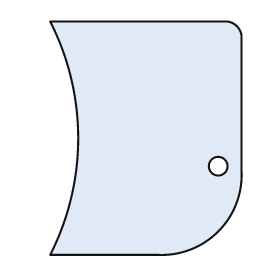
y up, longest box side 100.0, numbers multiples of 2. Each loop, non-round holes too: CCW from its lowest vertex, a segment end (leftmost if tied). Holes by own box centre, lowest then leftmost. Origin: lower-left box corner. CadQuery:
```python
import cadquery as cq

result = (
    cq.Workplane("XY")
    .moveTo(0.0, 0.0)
    .lineTo(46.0, 0.0)
    .threePointArc((72.0, 10.0), (82.0, 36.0))
    .lineTo(82.0, 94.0)
    .threePointArc((80.0, 98.0), (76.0, 100.0))
    .lineTo(0.0, 100.0)
    .threePointArc((12.0, 50.0), (0.0, 0.0))
    .close()
    .moveTo(72.0, 38.0)
    .circle(4.0)
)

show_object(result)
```